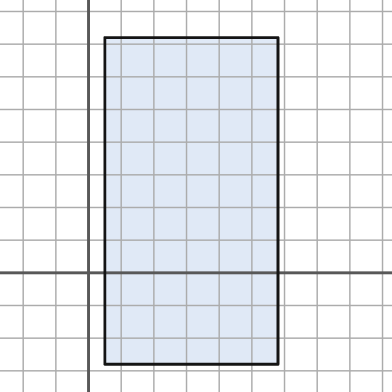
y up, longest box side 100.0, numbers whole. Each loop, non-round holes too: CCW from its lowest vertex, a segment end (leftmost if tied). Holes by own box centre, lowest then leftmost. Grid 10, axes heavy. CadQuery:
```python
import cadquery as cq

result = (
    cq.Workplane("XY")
    .moveTo(5.0, -28.0)
    .lineTo(58.0, -28.0)
    .lineTo(58.0, 72.0)
    .lineTo(5.0, 72.0)
    .close()
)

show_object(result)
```